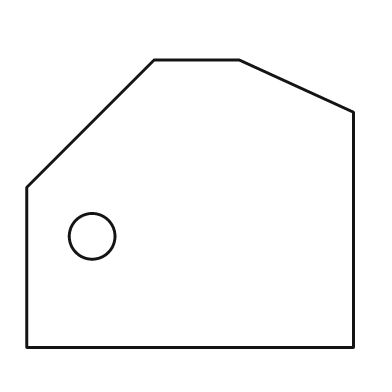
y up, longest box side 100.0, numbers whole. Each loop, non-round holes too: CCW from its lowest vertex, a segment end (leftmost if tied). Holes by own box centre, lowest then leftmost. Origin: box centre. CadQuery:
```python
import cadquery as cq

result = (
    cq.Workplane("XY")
    .moveTo(-50.0, -44.0)
    .lineTo(50.0, -44.0)
    .lineTo(50.0, 28.0)
    .lineTo(15.0, 44.0)
    .lineTo(-11.0, 44.0)
    .lineTo(-50.0, 5.0)
    .close()
    .moveTo(-30.0, -10.0)
    .circle(7.0)
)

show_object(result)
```